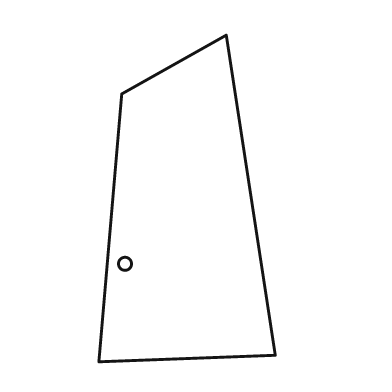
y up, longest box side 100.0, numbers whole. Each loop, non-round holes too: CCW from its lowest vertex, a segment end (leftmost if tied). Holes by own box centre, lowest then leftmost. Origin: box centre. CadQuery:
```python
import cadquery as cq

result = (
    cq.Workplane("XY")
    .moveTo(-27.0, -50.0)
    .lineTo(27.0, -48.0)
    .lineTo(12.0, 50.0)
    .lineTo(-20.0, 32.0)
    .close()
    .moveTo(-19.0, -20.0)
    .circle(2.0)
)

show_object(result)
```